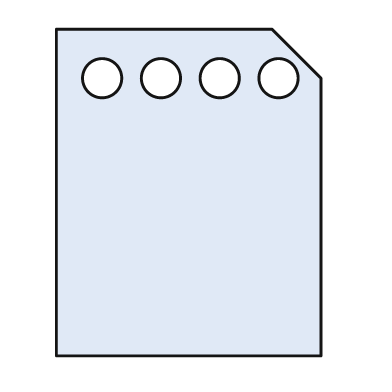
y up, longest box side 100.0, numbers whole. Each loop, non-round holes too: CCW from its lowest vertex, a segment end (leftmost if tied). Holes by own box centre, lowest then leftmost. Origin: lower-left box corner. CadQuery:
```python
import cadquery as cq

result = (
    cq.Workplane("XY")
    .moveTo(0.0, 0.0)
    .lineTo(81.0, 0.0)
    .lineTo(81.0, 85.0)
    .lineTo(66.0, 100.0)
    .lineTo(0.0, 100.0)
    .close()
    .moveTo(14.0, 85.0)
    .circle(6.0)
    .moveTo(32.0, 85.0)
    .circle(6.0)
    .moveTo(50.0, 85.0)
    .circle(6.0)
    .moveTo(68.0, 85.0)
    .circle(6.0)
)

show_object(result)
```